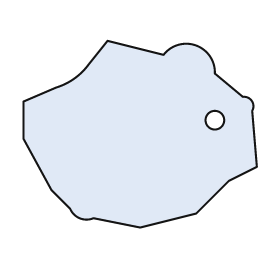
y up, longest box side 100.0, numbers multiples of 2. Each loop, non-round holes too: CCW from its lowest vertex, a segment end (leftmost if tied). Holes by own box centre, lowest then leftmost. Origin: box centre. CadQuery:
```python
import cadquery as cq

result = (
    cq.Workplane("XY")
    .moveTo(0.0, -40.0)
    .lineTo(24.0, -34.0)
    .lineTo(38.0, -20.0)
    .lineTo(50.0, -14.0)
    .lineTo(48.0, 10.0)
    .threePointArc((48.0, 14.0), (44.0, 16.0))
    .lineTo(32.0, 26.0)
    .threePointArc((24.0, 38.0), (10.0, 34.0))
    .lineTo(-14.0, 40.0)
    .lineTo(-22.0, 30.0)
    .threePointArc((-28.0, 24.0), (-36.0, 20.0))
    .lineTo(-50.0, 14.0)
    .lineTo(-50.0, -2.0)
    .lineTo(-38.0, -24.0)
    .lineTo(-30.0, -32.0)
    .threePointArc((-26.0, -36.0), (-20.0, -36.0))
    .close()
    .moveTo(32.0, 6.0)
    .circle(4.0)
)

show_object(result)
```